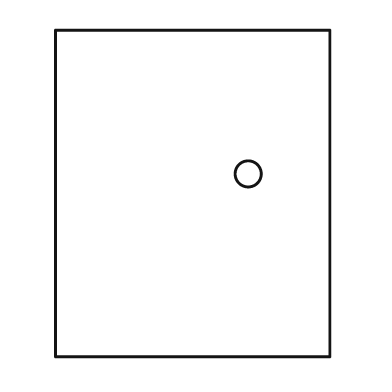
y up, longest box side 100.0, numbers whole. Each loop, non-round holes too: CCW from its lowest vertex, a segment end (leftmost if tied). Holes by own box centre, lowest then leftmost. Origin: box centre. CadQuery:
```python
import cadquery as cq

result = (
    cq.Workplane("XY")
    .moveTo(-42.0, -50.0)
    .lineTo(42.0, -50.0)
    .lineTo(42.0, 50.0)
    .lineTo(-42.0, 50.0)
    .close()
    .moveTo(17.0, 6.0)
    .circle(4.0)
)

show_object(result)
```